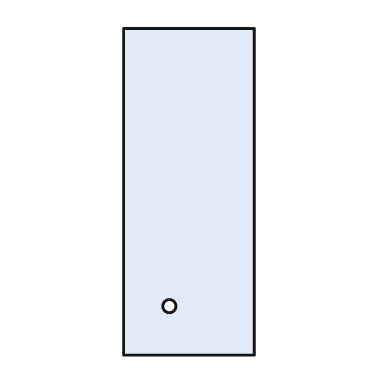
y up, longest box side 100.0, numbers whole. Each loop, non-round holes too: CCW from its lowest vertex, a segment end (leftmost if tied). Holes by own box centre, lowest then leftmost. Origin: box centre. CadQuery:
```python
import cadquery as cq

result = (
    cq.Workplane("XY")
    .moveTo(-20.0, -50.0)
    .lineTo(20.0, -50.0)
    .lineTo(20.0, 50.0)
    .lineTo(-20.0, 50.0)
    .close()
    .moveTo(-6.0, -35.0)
    .circle(2.0)
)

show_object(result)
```